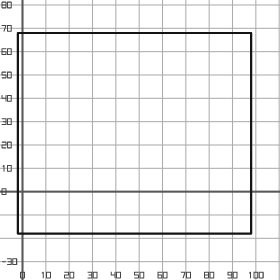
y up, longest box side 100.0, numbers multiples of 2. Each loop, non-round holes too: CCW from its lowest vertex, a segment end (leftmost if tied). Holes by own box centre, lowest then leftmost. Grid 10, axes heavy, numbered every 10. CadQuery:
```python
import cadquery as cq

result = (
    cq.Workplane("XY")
    .moveTo(-2.0, -18.0)
    .lineTo(98.0, -18.0)
    .lineTo(98.0, 68.0)
    .lineTo(-2.0, 68.0)
    .close()
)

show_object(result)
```